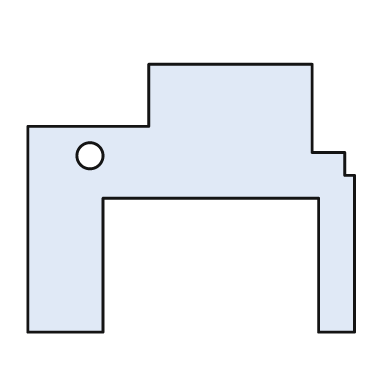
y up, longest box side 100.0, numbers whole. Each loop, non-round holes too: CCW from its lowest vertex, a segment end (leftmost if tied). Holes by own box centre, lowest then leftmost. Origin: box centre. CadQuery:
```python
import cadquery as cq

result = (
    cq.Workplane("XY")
    .moveTo(-50.0, -41.0)
    .lineTo(-27.0, -41.0)
    .lineTo(-27.0, 0.0)
    .lineTo(39.0, 0.0)
    .lineTo(39.0, -41.0)
    .lineTo(50.0, -41.0)
    .lineTo(50.0, 7.0)
    .lineTo(47.0, 7.0)
    .lineTo(47.0, 14.0)
    .lineTo(37.0, 14.0)
    .lineTo(37.0, 41.0)
    .lineTo(-13.0, 41.0)
    .lineTo(-13.0, 22.0)
    .lineTo(-50.0, 22.0)
    .close()
    .moveTo(-31.0, 13.0)
    .circle(4.0)
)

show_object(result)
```